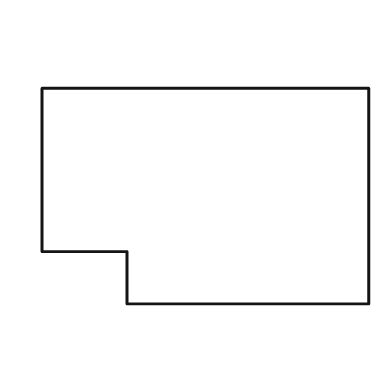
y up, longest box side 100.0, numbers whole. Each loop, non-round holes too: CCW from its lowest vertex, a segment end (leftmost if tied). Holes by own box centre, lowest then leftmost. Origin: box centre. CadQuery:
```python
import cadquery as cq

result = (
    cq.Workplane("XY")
    .moveTo(-24.0, -33.0)
    .lineTo(50.0, -33.0)
    .lineTo(50.0, 33.0)
    .lineTo(-50.0, 33.0)
    .lineTo(-50.0, -17.0)
    .lineTo(-24.0, -17.0)
    .close()
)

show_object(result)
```